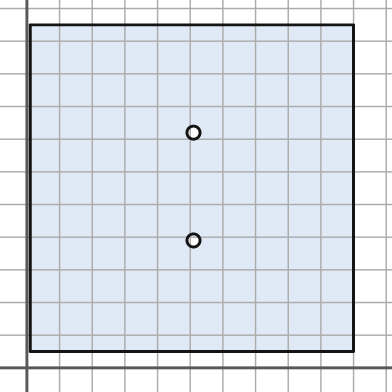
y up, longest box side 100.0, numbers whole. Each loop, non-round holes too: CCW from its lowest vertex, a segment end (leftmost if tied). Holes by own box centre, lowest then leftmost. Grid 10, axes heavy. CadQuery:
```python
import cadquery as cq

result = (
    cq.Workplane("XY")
    .moveTo(1.0, 5.0)
    .lineTo(100.0, 5.0)
    .lineTo(100.0, 105.0)
    .lineTo(1.0, 105.0)
    .close()
    .moveTo(51.0, 39.0)
    .circle(2.0)
    .moveTo(51.0, 72.0)
    .circle(2.0)
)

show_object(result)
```